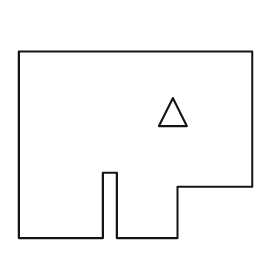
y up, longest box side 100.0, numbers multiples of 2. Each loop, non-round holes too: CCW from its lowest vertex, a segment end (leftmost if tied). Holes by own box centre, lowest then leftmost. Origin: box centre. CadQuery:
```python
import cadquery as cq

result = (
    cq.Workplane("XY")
    .moveTo(-50.0, -40.0)
    .lineTo(-14.0, -40.0)
    .lineTo(-14.0, -12.0)
    .lineTo(-8.0, -12.0)
    .lineTo(-8.0, -40.0)
    .lineTo(18.0, -40.0)
    .lineTo(18.0, -18.0)
    .lineTo(50.0, -18.0)
    .lineTo(50.0, 40.0)
    .lineTo(-50.0, 40.0)
    .close()
    .moveTo(10.0, 8.0)
    .lineTo(22.0, 8.0)
    .lineTo(16.0, 20.0)
    .close()
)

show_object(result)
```